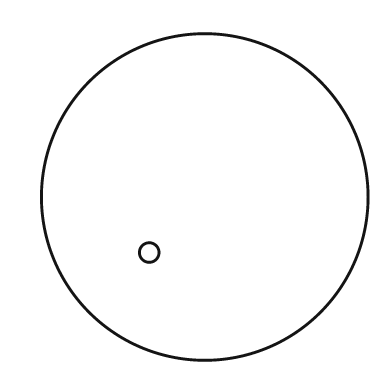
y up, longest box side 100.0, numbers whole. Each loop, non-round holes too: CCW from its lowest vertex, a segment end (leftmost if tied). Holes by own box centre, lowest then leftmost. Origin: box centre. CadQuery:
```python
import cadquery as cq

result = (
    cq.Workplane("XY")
    .moveTo(0.0, 0.0)
    .circle(50.0)
    .moveTo(-17.0, -17.0)
    .circle(3.0)
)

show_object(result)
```